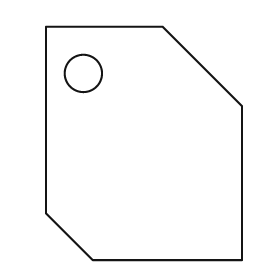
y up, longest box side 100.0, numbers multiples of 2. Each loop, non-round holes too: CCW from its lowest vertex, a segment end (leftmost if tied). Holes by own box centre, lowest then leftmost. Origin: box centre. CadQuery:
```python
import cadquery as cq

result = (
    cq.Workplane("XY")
    .moveTo(-22.0, -50.0)
    .lineTo(42.0, -50.0)
    .lineTo(42.0, 16.0)
    .lineTo(8.0, 50.0)
    .lineTo(-42.0, 50.0)
    .lineTo(-42.0, -30.0)
    .close()
    .moveTo(-26.0, 30.0)
    .circle(8.0)
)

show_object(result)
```